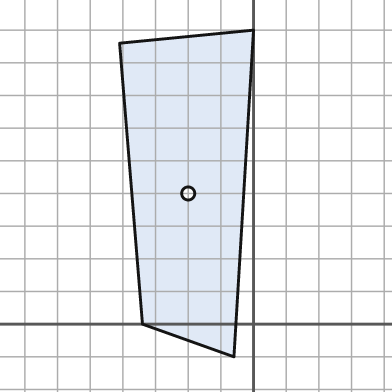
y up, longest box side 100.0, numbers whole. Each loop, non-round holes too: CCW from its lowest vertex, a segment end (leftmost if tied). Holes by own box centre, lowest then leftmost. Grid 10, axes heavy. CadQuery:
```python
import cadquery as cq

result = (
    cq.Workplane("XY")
    .moveTo(-6.0, -10.0)
    .lineTo(0.0, 90.0)
    .lineTo(-41.0, 86.0)
    .lineTo(-34.0, 0.0)
    .close()
    .moveTo(-20.0, 40.0)
    .circle(2.0)
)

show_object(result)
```